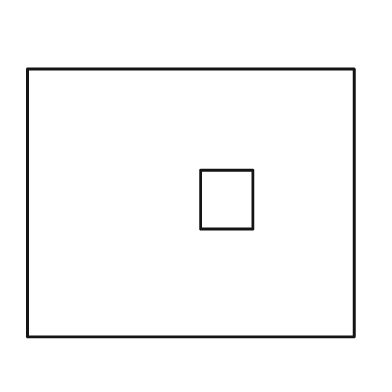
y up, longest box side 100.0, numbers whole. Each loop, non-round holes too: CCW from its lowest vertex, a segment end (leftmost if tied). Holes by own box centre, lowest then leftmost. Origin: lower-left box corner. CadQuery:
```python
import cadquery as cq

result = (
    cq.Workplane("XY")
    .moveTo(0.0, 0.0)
    .lineTo(100.0, 0.0)
    .lineTo(100.0, 82.0)
    .lineTo(0.0, 82.0)
    .close()
    .moveTo(53.0, 33.0)
    .lineTo(69.0, 33.0)
    .lineTo(69.0, 51.0)
    .lineTo(53.0, 51.0)
    .close()
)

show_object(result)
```